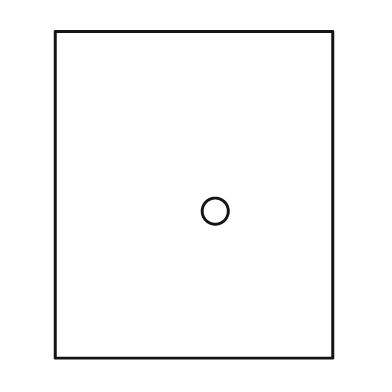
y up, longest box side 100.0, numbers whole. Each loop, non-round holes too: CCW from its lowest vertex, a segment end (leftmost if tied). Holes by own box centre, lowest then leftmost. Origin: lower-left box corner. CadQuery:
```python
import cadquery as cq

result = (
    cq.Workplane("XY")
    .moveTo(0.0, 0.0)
    .lineTo(85.0, 0.0)
    .lineTo(85.0, 100.0)
    .lineTo(0.0, 100.0)
    .close()
    .moveTo(49.0, 45.0)
    .circle(4.0)
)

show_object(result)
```